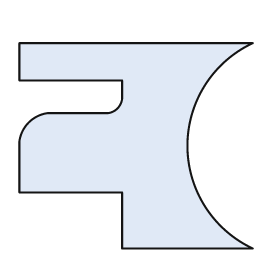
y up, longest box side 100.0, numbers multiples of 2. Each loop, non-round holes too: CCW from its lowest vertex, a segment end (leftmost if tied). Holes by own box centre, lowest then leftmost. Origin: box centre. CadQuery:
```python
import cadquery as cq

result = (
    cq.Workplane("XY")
    .moveTo(-6.0, -44.0)
    .lineTo(50.0, -44.0)
    .threePointArc((22.0, 0.0), (50.0, 44.0))
    .lineTo(-50.0, 44.0)
    .lineTo(-50.0, 28.0)
    .lineTo(-6.0, 28.0)
    .lineTo(-6.0, 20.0)
    .threePointArc((-8.0, 16.0), (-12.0, 14.0))
    .lineTo(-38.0, 14.0)
    .threePointArc((-46.0, 10.0), (-50.0, 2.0))
    .lineTo(-50.0, -20.0)
    .lineTo(-6.0, -20.0)
    .close()
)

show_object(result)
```